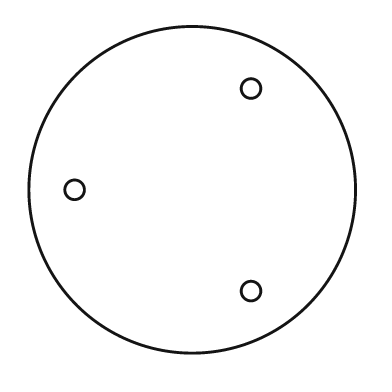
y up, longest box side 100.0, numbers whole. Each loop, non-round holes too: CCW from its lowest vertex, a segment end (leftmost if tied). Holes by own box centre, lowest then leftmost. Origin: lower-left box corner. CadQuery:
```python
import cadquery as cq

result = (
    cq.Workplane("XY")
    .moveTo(50.0, 50.0)
    .circle(50.0)
    .moveTo(68.0, 19.0)
    .circle(3.0)
    .moveTo(14.0, 50.0)
    .circle(3.0)
    .moveTo(68.0, 81.0)
    .circle(3.0)
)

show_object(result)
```